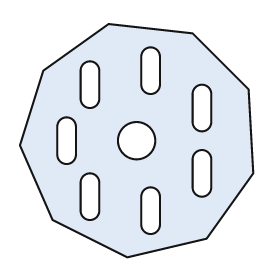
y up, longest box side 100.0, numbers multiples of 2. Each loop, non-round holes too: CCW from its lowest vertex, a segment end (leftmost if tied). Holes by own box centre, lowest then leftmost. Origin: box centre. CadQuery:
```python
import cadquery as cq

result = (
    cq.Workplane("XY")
    .moveTo(-4.0, -50.0)
    .lineTo(30.0, -42.0)
    .lineTo(50.0, -14.0)
    .lineTo(48.0, 22.0)
    .lineTo(24.0, 46.0)
    .lineTo(-12.0, 50.0)
    .lineTo(-40.0, 30.0)
    .lineTo(-50.0, -2.0)
    .lineTo(-36.0, -34.0)
    .close()
    .moveTo(2.0, -36.0)
    .threePointArc((6.0, -40.0), (10.0, -36.0))
    .lineTo(10.0, -24.0)
    .threePointArc((6.0, -20.0), (2.0, -24.0))
    .close()
    .moveTo(-24.0, -30.0)
    .threePointArc((-20.0, -34.0), (-16.0, -30.0))
    .lineTo(-16.0, -18.0)
    .threePointArc((-20.0, -14.0), (-24.0, -18.0))
    .close()
    .moveTo(24.0, -20.0)
    .threePointArc((28.0, -24.0), (32.0, -20.0))
    .lineTo(32.0, -8.0)
    .threePointArc((28.0, -4.0), (24.0, -8.0))
    .close()
    .moveTo(-34.0, -6.0)
    .threePointArc((-30.0, -10.0), (-26.0, -6.0))
    .lineTo(-26.0, 6.0)
    .threePointArc((-30.0, 10.0), (-34.0, 6.0))
    .close()
    .moveTo(0.0, 0.0)
    .circle(8.0)
    .moveTo(24.0, 8.0)
    .threePointArc((28.0, 4.0), (32.0, 8.0))
    .lineTo(32.0, 20.0)
    .threePointArc((28.0, 24.0), (24.0, 20.0))
    .close()
    .moveTo(-24.0, 18.0)
    .threePointArc((-20.0, 14.0), (-16.0, 18.0))
    .lineTo(-16.0, 30.0)
    .threePointArc((-20.0, 34.0), (-24.0, 30.0))
    .close()
    .moveTo(2.0, 24.0)
    .threePointArc((6.0, 20.0), (10.0, 24.0))
    .lineTo(10.0, 36.0)
    .threePointArc((6.0, 40.0), (2.0, 36.0))
    .close()
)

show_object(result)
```